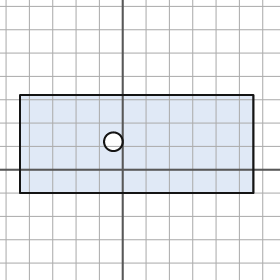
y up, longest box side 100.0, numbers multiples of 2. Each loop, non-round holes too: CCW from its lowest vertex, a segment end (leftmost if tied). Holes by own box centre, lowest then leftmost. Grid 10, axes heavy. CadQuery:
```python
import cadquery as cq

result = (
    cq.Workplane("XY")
    .moveTo(-44.0, -10.0)
    .lineTo(56.0, -10.0)
    .lineTo(56.0, 32.0)
    .lineTo(-44.0, 32.0)
    .close()
    .moveTo(-4.0, 12.0)
    .circle(4.0)
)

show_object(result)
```